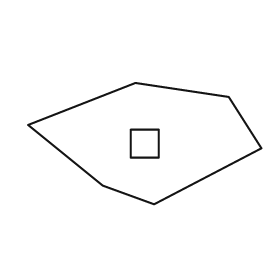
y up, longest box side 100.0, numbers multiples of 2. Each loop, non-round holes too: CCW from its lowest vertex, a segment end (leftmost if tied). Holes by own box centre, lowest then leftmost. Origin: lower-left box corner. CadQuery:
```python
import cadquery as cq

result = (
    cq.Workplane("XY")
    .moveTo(54.0, 0.0)
    .lineTo(100.0, 24.0)
    .lineTo(86.0, 46.0)
    .lineTo(46.0, 52.0)
    .lineTo(0.0, 34.0)
    .lineTo(32.0, 8.0)
    .close()
    .moveTo(44.0, 20.0)
    .lineTo(56.0, 20.0)
    .lineTo(56.0, 32.0)
    .lineTo(44.0, 32.0)
    .close()
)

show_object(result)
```